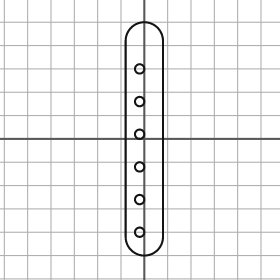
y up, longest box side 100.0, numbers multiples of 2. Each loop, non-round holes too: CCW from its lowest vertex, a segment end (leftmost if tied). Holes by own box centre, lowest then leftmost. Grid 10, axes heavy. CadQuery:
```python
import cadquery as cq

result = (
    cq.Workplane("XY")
    .moveTo(-8.0, -42.0)
    .threePointArc((0.0, -50.0), (8.0, -42.0))
    .lineTo(8.0, 42.0)
    .threePointArc((0.0, 50.0), (-8.0, 42.0))
    .close()
    .moveTo(-2.0, -40.0)
    .circle(2.0)
    .moveTo(-2.0, -26.0)
    .circle(2.0)
    .moveTo(-2.0, -12.0)
    .circle(2.0)
    .moveTo(-2.0, 2.0)
    .circle(2.0)
    .moveTo(-2.0, 16.0)
    .circle(2.0)
    .moveTo(-2.0, 30.0)
    .circle(2.0)
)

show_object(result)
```